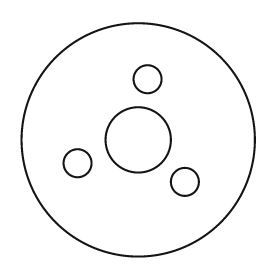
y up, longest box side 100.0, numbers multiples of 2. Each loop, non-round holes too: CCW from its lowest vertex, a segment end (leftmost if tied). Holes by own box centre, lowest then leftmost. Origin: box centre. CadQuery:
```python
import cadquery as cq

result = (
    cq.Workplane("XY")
    .moveTo(0.0, 0.0)
    .circle(50.0)
    .moveTo(20.0, -18.0)
    .circle(6.0)
    .moveTo(-26.0, -10.0)
    .circle(6.0)
    .moveTo(0.0, 0.0)
    .circle(14.0)
    .moveTo(4.0, 26.0)
    .circle(6.0)
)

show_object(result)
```